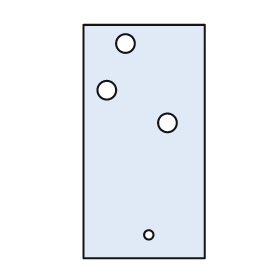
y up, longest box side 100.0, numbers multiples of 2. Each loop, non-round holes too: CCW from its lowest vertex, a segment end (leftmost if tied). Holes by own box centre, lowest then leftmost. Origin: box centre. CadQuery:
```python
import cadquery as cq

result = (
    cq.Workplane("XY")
    .moveTo(-26.0, -50.0)
    .lineTo(26.0, -50.0)
    .lineTo(26.0, 50.0)
    .lineTo(-26.0, 50.0)
    .close()
    .moveTo(2.0, -40.0)
    .circle(2.0)
    .moveTo(10.0, 8.0)
    .circle(4.0)
    .moveTo(-16.0, 22.0)
    .circle(4.0)
    .moveTo(-8.0, 42.0)
    .circle(4.0)
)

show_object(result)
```